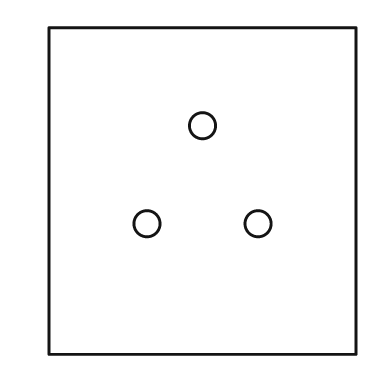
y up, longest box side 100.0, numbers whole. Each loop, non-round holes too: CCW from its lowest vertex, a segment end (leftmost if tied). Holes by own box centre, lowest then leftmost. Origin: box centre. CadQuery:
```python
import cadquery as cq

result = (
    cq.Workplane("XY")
    .moveTo(-47.0, -50.0)
    .lineTo(47.0, -50.0)
    .lineTo(47.0, 50.0)
    .lineTo(-47.0, 50.0)
    .close()
    .moveTo(-17.0, -10.0)
    .circle(4.0)
    .moveTo(17.0, -10.0)
    .circle(4.0)
    .moveTo(0.0, 20.0)
    .circle(4.0)
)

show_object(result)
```